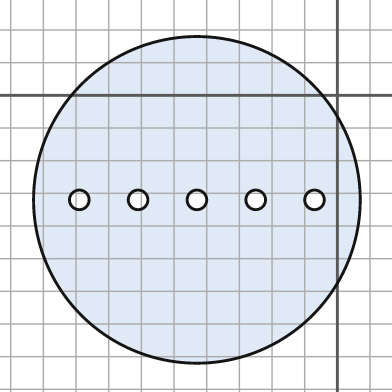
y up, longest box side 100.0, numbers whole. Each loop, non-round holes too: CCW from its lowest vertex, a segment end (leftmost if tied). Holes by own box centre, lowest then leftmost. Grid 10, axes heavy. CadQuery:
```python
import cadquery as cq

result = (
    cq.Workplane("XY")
    .moveTo(-43.0, -32.0)
    .circle(50.0)
    .moveTo(-79.0, -32.0)
    .circle(3.0)
    .moveTo(-61.0, -32.0)
    .circle(3.0)
    .moveTo(-43.0, -32.0)
    .circle(3.0)
    .moveTo(-25.0, -32.0)
    .circle(3.0)
    .moveTo(-7.0, -32.0)
    .circle(3.0)
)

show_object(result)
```